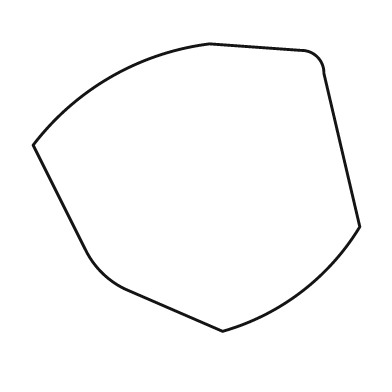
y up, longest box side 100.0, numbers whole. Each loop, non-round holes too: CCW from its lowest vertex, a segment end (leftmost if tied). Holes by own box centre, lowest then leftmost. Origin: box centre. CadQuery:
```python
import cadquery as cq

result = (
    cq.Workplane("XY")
    .moveTo(8.0, -44.0)
    .threePointArc((32.0, -32.0), (50.0, -12.0))
    .lineTo(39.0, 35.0)
    .threePointArc((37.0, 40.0), (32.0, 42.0))
    .lineTo(4.0, 44.0)
    .threePointArc((-26.0, 34.0), (-50.0, 13.0))
    .lineTo(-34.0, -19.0)
    .threePointArc((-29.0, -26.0), (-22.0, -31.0))
    .close()
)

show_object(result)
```